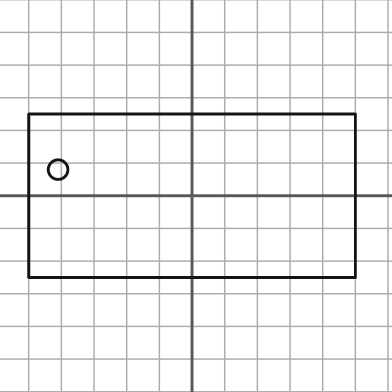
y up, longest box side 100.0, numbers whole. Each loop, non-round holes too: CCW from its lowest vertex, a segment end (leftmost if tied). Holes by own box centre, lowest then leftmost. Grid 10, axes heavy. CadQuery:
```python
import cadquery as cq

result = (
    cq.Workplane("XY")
    .moveTo(-50.0, -25.0)
    .lineTo(50.0, -25.0)
    .lineTo(50.0, 25.0)
    .lineTo(-50.0, 25.0)
    .close()
    .moveTo(-41.0, 8.0)
    .circle(3.0)
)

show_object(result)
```